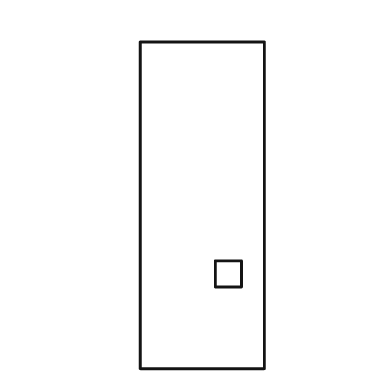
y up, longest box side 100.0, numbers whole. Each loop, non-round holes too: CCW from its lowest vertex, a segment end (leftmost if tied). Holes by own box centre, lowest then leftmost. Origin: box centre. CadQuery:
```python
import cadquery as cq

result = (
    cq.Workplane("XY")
    .moveTo(-19.0, -50.0)
    .lineTo(19.0, -50.0)
    .lineTo(19.0, 50.0)
    .lineTo(-19.0, 50.0)
    .close()
    .moveTo(4.0, -25.0)
    .lineTo(12.0, -25.0)
    .lineTo(12.0, -17.0)
    .lineTo(4.0, -17.0)
    .close()
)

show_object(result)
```